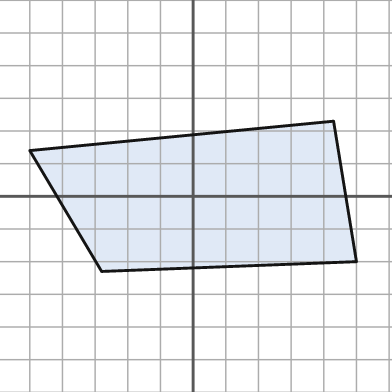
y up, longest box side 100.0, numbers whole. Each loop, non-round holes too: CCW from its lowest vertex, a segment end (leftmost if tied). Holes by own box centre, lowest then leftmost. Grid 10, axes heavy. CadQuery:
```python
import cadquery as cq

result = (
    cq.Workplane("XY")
    .moveTo(-28.0, -23.0)
    .lineTo(50.0, -20.0)
    .lineTo(43.0, 23.0)
    .lineTo(-50.0, 14.0)
    .close()
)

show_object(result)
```